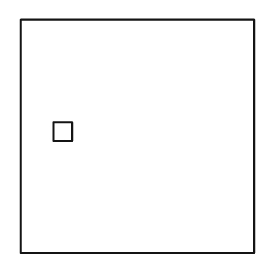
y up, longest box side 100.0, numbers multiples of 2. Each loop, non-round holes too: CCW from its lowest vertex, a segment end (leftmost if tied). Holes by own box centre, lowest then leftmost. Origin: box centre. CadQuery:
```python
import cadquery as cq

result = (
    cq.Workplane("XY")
    .moveTo(-50.0, -50.0)
    .lineTo(50.0, -50.0)
    .lineTo(50.0, 50.0)
    .lineTo(-50.0, 50.0)
    .close()
    .moveTo(-36.0, -2.0)
    .lineTo(-28.0, -2.0)
    .lineTo(-28.0, 6.0)
    .lineTo(-36.0, 6.0)
    .close()
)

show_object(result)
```